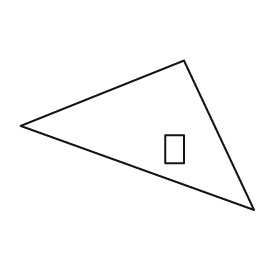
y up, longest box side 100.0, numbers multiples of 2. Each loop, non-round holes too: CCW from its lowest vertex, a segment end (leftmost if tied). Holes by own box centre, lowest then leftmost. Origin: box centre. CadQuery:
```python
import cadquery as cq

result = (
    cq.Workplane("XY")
    .moveTo(50.0, -32.0)
    .lineTo(20.0, 32.0)
    .lineTo(-50.0, 4.0)
    .close()
    .moveTo(12.0, -12.0)
    .lineTo(20.0, -12.0)
    .lineTo(20.0, 0.0)
    .lineTo(12.0, 0.0)
    .close()
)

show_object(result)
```